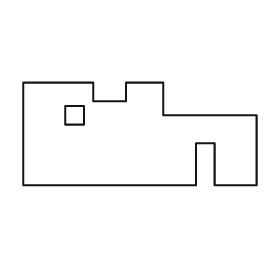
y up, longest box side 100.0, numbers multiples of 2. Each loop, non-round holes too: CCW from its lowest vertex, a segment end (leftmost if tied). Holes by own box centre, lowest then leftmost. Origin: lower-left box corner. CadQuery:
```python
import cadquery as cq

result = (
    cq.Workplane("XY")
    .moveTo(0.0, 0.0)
    .lineTo(74.0, 0.0)
    .lineTo(74.0, 18.0)
    .lineTo(82.0, 18.0)
    .lineTo(82.0, 0.0)
    .lineTo(100.0, 0.0)
    .lineTo(100.0, 30.0)
    .lineTo(60.0, 30.0)
    .lineTo(60.0, 44.0)
    .lineTo(44.0, 44.0)
    .lineTo(44.0, 36.0)
    .lineTo(30.0, 36.0)
    .lineTo(30.0, 44.0)
    .lineTo(0.0, 44.0)
    .close()
    .moveTo(18.0, 26.0)
    .lineTo(26.0, 26.0)
    .lineTo(26.0, 34.0)
    .lineTo(18.0, 34.0)
    .close()
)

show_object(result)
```